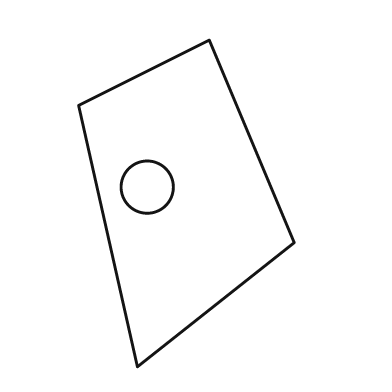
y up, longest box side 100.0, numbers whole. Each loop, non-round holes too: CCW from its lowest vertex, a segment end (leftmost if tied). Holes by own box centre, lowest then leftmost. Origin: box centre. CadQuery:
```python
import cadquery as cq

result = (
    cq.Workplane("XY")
    .moveTo(-15.0, -50.0)
    .lineTo(33.0, -12.0)
    .lineTo(7.0, 50.0)
    .lineTo(-33.0, 30.0)
    .close()
    .moveTo(-12.0, 5.0)
    .circle(8.0)
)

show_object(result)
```